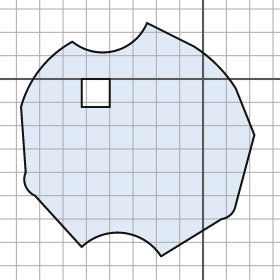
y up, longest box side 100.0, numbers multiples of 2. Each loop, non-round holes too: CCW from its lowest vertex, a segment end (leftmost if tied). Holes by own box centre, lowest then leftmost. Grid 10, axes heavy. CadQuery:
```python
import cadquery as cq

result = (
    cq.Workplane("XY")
    .moveTo(-18.0, -76.0)
    .lineTo(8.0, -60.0)
    .threePointArc((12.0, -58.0), (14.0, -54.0))
    .lineTo(22.0, -24.0)
    .lineTo(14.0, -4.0)
    .threePointArc((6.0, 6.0), (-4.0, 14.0))
    .lineTo(-24.0, 24.0)
    .threePointArc((-38.0, 12.0), (-56.0, 16.0))
    .threePointArc((-70.0, 4.0), (-78.0, -12.0))
    .lineTo(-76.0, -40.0)
    .threePointArc((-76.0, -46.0), (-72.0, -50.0))
    .lineTo(-52.0, -72.0)
    .threePointArc((-34.0, -66.0), (-18.0, -76.0))
    .close()
    .moveTo(-52.0, -12.0)
    .lineTo(-40.0, -12.0)
    .lineTo(-40.0, 0.0)
    .lineTo(-52.0, 0.0)
    .close()
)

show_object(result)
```